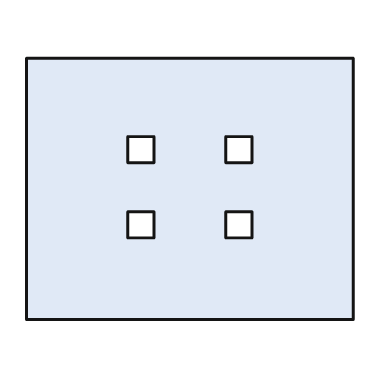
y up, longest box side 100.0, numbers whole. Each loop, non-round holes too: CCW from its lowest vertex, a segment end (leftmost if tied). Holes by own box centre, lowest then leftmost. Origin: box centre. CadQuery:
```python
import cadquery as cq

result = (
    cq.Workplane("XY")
    .moveTo(-50.0, -40.0)
    .lineTo(50.0, -40.0)
    .lineTo(50.0, 40.0)
    .lineTo(-50.0, 40.0)
    .close()
    .moveTo(-19.0, -15.0)
    .lineTo(-11.0, -15.0)
    .lineTo(-11.0, -7.0)
    .lineTo(-19.0, -7.0)
    .close()
    .moveTo(11.0, -15.0)
    .lineTo(19.0, -15.0)
    .lineTo(19.0, -7.0)
    .lineTo(11.0, -7.0)
    .close()
    .moveTo(-19.0, 8.0)
    .lineTo(-11.0, 8.0)
    .lineTo(-11.0, 16.0)
    .lineTo(-19.0, 16.0)
    .close()
    .moveTo(11.0, 8.0)
    .lineTo(19.0, 8.0)
    .lineTo(19.0, 16.0)
    .lineTo(11.0, 16.0)
    .close()
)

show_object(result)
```